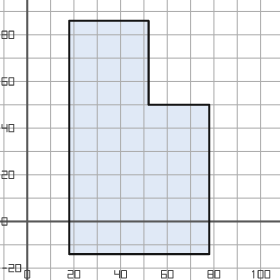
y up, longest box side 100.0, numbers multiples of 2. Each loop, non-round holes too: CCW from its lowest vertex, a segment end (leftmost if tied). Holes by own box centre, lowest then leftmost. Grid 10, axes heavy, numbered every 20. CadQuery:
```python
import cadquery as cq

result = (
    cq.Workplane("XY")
    .moveTo(18.0, -14.0)
    .lineTo(78.0, -14.0)
    .lineTo(78.0, 50.0)
    .lineTo(52.0, 50.0)
    .lineTo(52.0, 86.0)
    .lineTo(18.0, 86.0)
    .close()
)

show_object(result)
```